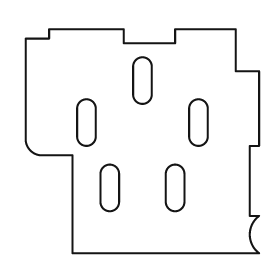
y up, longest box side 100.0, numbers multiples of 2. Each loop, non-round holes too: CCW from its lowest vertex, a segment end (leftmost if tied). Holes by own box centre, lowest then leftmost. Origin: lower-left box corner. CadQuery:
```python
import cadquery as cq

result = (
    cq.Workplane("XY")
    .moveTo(20.0, 0.0)
    .lineTo(100.0, 0.0)
    .threePointArc((96.0, 8.0), (100.0, 16.0))
    .lineTo(96.0, 16.0)
    .lineTo(96.0, 46.0)
    .lineTo(100.0, 46.0)
    .lineTo(100.0, 78.0)
    .lineTo(90.0, 78.0)
    .lineTo(90.0, 96.0)
    .lineTo(64.0, 96.0)
    .lineTo(64.0, 90.0)
    .lineTo(42.0, 90.0)
    .lineTo(42.0, 96.0)
    .lineTo(10.0, 96.0)
    .lineTo(10.0, 92.0)
    .lineTo(0.0, 92.0)
    .lineTo(0.0, 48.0)
    .threePointArc((2.0, 44.0), (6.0, 42.0))
    .lineTo(20.0, 42.0)
    .close()
    .moveTo(32.0, 22.0)
    .threePointArc((36.0, 18.0), (40.0, 22.0))
    .lineTo(40.0, 34.0)
    .threePointArc((36.0, 38.0), (32.0, 34.0))
    .close()
    .moveTo(60.0, 22.0)
    .threePointArc((64.0, 18.0), (68.0, 22.0))
    .lineTo(68.0, 34.0)
    .threePointArc((64.0, 38.0), (60.0, 34.0))
    .close()
    .moveTo(22.0, 50.0)
    .threePointArc((26.0, 46.0), (30.0, 50.0))
    .lineTo(30.0, 62.0)
    .threePointArc((26.0, 66.0), (22.0, 62.0))
    .close()
    .moveTo(70.0, 50.0)
    .threePointArc((74.0, 46.0), (78.0, 50.0))
    .lineTo(78.0, 62.0)
    .threePointArc((74.0, 66.0), (70.0, 62.0))
    .close()
    .moveTo(46.0, 68.0)
    .threePointArc((50.0, 64.0), (54.0, 68.0))
    .lineTo(54.0, 80.0)
    .threePointArc((50.0, 84.0), (46.0, 80.0))
    .close()
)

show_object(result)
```